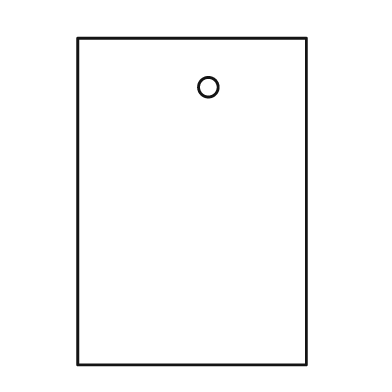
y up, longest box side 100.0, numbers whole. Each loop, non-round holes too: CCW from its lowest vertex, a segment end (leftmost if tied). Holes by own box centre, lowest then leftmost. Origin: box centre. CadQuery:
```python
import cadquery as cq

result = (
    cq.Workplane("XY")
    .moveTo(-35.0, -50.0)
    .lineTo(35.0, -50.0)
    .lineTo(35.0, 50.0)
    .lineTo(-35.0, 50.0)
    .close()
    .moveTo(5.0, 35.0)
    .circle(3.0)
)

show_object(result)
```